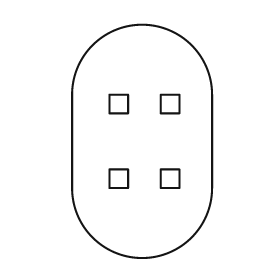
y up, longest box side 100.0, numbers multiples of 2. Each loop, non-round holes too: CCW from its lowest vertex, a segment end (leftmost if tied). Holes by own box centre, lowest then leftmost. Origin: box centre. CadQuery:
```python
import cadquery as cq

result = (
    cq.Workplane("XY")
    .moveTo(-30.0, -20.0)
    .threePointArc((0.0, -50.0), (30.0, -20.0))
    .lineTo(30.0, 20.0)
    .threePointArc((0.0, 50.0), (-30.0, 20.0))
    .close()
    .moveTo(-14.0, -20.0)
    .lineTo(-6.0, -20.0)
    .lineTo(-6.0, -12.0)
    .lineTo(-14.0, -12.0)
    .close()
    .moveTo(8.0, -20.0)
    .lineTo(16.0, -20.0)
    .lineTo(16.0, -12.0)
    .lineTo(8.0, -12.0)
    .close()
    .moveTo(-14.0, 12.0)
    .lineTo(-6.0, 12.0)
    .lineTo(-6.0, 20.0)
    .lineTo(-14.0, 20.0)
    .close()
    .moveTo(8.0, 12.0)
    .lineTo(16.0, 12.0)
    .lineTo(16.0, 20.0)
    .lineTo(8.0, 20.0)
    .close()
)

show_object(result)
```